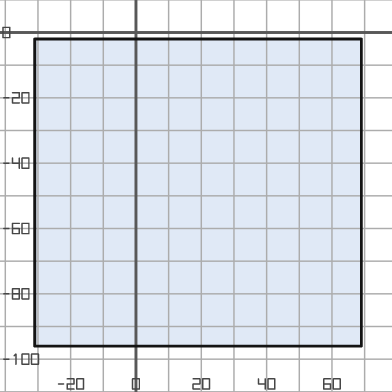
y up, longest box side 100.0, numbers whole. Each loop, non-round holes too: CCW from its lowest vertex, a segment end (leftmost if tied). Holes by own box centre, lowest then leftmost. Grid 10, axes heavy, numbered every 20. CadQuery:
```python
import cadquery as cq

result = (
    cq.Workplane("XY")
    .moveTo(-31.0, -96.0)
    .lineTo(69.0, -96.0)
    .lineTo(69.0, -2.0)
    .lineTo(-31.0, -2.0)
    .close()
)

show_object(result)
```